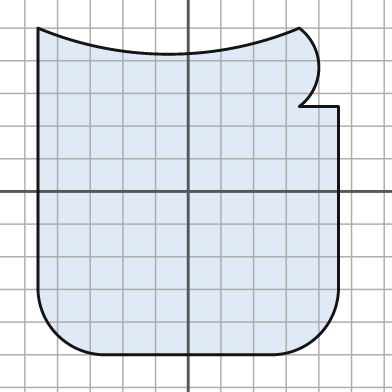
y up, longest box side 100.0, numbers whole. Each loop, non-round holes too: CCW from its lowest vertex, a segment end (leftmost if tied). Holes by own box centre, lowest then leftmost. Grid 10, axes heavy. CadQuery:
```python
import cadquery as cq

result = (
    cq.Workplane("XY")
    .moveTo(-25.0, -50.0)
    .lineTo(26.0, -50.0)
    .threePointArc((40.0, -44.0), (46.0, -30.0))
    .lineTo(46.0, 26.0)
    .lineTo(34.0, 26.0)
    .threePointArc((40.0, 38.0), (34.0, 50.0))
    .threePointArc((-6.0, 42.0), (-46.0, 50.0))
    .lineTo(-46.0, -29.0)
    .threePointArc((-40.0, -44.0), (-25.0, -50.0))
    .close()
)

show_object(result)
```